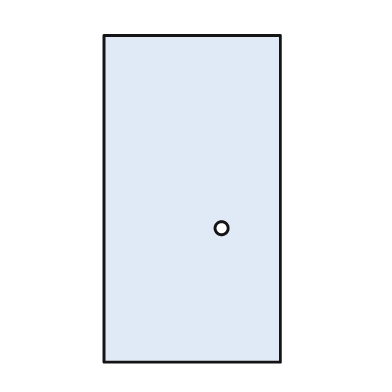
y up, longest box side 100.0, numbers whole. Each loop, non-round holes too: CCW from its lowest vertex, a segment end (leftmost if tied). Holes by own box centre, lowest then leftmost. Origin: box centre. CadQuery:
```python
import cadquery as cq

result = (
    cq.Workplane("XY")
    .moveTo(-27.0, -50.0)
    .lineTo(27.0, -50.0)
    .lineTo(27.0, 50.0)
    .lineTo(-27.0, 50.0)
    .close()
    .moveTo(9.0, -9.0)
    .circle(2.0)
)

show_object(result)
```